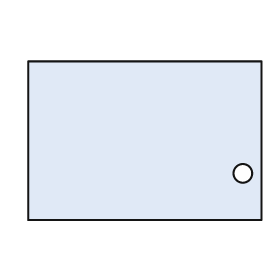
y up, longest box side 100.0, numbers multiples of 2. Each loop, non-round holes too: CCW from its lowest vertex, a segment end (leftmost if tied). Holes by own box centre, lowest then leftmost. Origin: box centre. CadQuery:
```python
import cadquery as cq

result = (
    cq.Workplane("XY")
    .moveTo(-50.0, -34.0)
    .lineTo(50.0, -34.0)
    .lineTo(50.0, 34.0)
    .lineTo(-50.0, 34.0)
    .close()
    .moveTo(42.0, -14.0)
    .circle(4.0)
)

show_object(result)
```